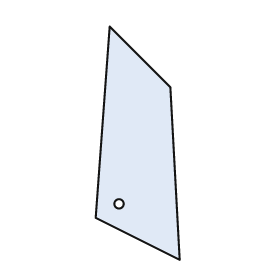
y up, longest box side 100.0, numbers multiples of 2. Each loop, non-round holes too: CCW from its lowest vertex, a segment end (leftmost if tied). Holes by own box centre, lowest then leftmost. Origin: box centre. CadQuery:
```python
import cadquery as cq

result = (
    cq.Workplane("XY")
    .moveTo(18.0, -50.0)
    .lineTo(14.0, 24.0)
    .lineTo(-12.0, 50.0)
    .lineTo(-18.0, -32.0)
    .close()
    .moveTo(-8.0, -26.0)
    .circle(2.0)
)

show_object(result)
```